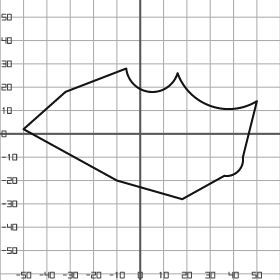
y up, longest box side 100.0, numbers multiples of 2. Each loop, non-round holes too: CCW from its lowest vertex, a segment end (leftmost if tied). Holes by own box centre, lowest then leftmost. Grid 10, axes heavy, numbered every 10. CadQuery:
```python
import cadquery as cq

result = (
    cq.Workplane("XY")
    .moveTo(18.0, -28.0)
    .lineTo(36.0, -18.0)
    .threePointArc((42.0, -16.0), (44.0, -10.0))
    .lineTo(50.0, 14.0)
    .threePointArc((30.0, 12.0), (16.0, 26.0))
    .threePointArc((4.0, 18.0), (-6.0, 28.0))
    .lineTo(-32.0, 18.0)
    .lineTo(-50.0, 2.0)
    .lineTo(-10.0, -20.0)
    .close()
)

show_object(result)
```